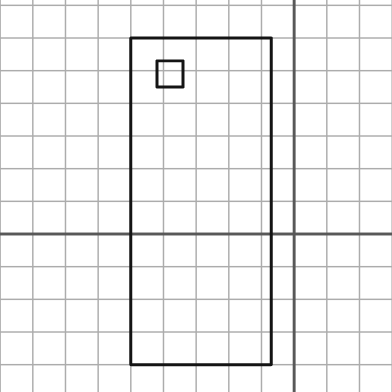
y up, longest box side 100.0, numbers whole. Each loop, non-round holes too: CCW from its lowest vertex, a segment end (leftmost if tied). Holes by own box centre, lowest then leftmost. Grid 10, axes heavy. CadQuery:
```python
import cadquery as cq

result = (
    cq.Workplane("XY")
    .moveTo(-50.0, -40.0)
    .lineTo(-7.0, -40.0)
    .lineTo(-7.0, 60.0)
    .lineTo(-50.0, 60.0)
    .close()
    .moveTo(-42.0, 45.0)
    .lineTo(-34.0, 45.0)
    .lineTo(-34.0, 53.0)
    .lineTo(-42.0, 53.0)
    .close()
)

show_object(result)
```